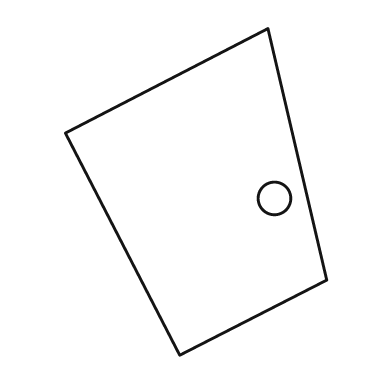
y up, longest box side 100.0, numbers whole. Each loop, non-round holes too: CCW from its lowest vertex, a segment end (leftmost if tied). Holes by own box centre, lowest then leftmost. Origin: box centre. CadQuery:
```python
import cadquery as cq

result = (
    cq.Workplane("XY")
    .moveTo(-5.0, -50.0)
    .lineTo(40.0, -27.0)
    .lineTo(22.0, 50.0)
    .lineTo(-40.0, 18.0)
    .close()
    .moveTo(24.0, -2.0)
    .circle(5.0)
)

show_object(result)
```